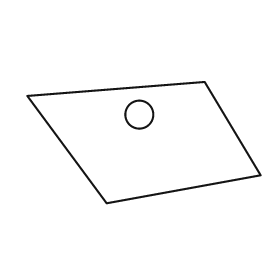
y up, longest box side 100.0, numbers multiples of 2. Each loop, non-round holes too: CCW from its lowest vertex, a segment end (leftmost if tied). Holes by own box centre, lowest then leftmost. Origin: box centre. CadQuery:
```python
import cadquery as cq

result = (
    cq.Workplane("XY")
    .moveTo(-16.0, -26.0)
    .lineTo(50.0, -14.0)
    .lineTo(26.0, 26.0)
    .lineTo(-50.0, 20.0)
    .close()
    .moveTo(-2.0, 12.0)
    .circle(6.0)
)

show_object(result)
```